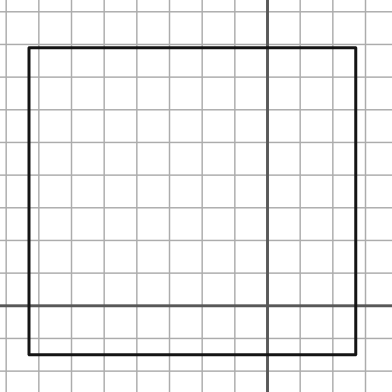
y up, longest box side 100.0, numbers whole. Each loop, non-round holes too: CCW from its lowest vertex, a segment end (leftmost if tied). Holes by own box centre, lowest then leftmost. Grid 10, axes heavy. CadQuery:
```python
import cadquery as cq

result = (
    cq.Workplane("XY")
    .moveTo(-73.0, -15.0)
    .lineTo(27.0, -15.0)
    .lineTo(27.0, 79.0)
    .lineTo(-73.0, 79.0)
    .close()
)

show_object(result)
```